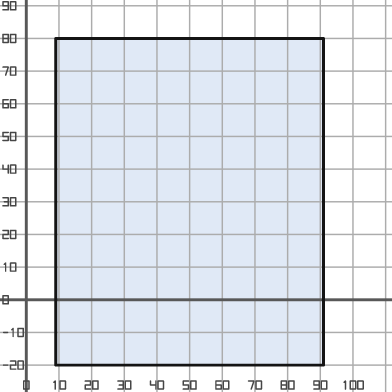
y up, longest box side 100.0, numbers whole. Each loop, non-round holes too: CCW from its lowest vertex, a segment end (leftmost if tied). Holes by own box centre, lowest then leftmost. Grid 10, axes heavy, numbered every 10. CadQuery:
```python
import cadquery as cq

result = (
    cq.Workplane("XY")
    .moveTo(9.0, -20.0)
    .lineTo(91.0, -20.0)
    .lineTo(91.0, 80.0)
    .lineTo(9.0, 80.0)
    .close()
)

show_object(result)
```